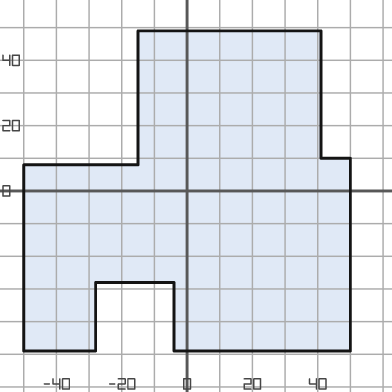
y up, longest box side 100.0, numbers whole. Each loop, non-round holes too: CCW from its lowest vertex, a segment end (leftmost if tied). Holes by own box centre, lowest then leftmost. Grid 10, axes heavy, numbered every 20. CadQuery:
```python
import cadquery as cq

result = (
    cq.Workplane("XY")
    .moveTo(-50.0, -49.0)
    .lineTo(-28.0, -49.0)
    .lineTo(-28.0, -28.0)
    .lineTo(-4.0, -28.0)
    .lineTo(-4.0, -49.0)
    .lineTo(50.0, -49.0)
    .lineTo(50.0, 10.0)
    .lineTo(41.0, 10.0)
    .lineTo(41.0, 49.0)
    .lineTo(-15.0, 49.0)
    .lineTo(-15.0, 8.0)
    .lineTo(-50.0, 8.0)
    .close()
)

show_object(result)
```